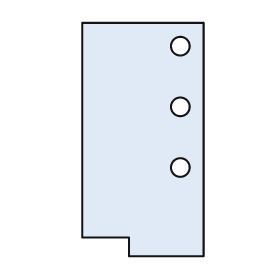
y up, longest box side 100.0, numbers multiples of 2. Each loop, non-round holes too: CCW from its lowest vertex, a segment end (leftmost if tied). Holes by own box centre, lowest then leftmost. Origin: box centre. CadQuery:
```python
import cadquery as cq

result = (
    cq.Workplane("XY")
    .moveTo(-6.0, -50.0)
    .lineTo(26.0, -50.0)
    .lineTo(26.0, 50.0)
    .lineTo(-26.0, 50.0)
    .lineTo(-26.0, -42.0)
    .lineTo(-6.0, -42.0)
    .close()
    .moveTo(16.0, -12.0)
    .circle(4.0)
    .moveTo(16.0, 14.0)
    .circle(4.0)
    .moveTo(16.0, 40.0)
    .circle(4.0)
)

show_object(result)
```